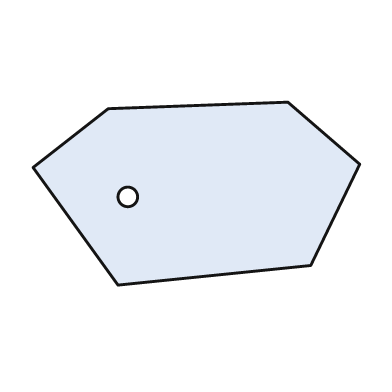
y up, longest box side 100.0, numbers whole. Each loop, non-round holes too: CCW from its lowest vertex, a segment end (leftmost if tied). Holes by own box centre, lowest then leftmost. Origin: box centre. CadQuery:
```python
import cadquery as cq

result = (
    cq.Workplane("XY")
    .moveTo(-24.0, -28.0)
    .lineTo(35.0, -22.0)
    .lineTo(50.0, 9.0)
    .lineTo(28.0, 28.0)
    .lineTo(-27.0, 26.0)
    .lineTo(-50.0, 8.0)
    .close()
    .moveTo(-21.0, -1.0)
    .circle(3.0)
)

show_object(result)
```